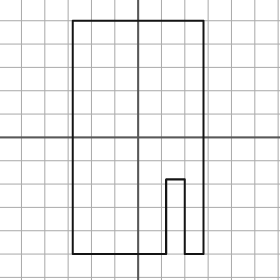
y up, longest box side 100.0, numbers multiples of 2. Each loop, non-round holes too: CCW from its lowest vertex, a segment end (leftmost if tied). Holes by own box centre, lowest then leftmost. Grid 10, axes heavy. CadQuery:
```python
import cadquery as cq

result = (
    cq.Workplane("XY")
    .moveTo(-28.0, -50.0)
    .lineTo(12.0, -50.0)
    .lineTo(12.0, -18.0)
    .lineTo(20.0, -18.0)
    .lineTo(20.0, -50.0)
    .lineTo(28.0, -50.0)
    .lineTo(28.0, 50.0)
    .lineTo(-28.0, 50.0)
    .close()
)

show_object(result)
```